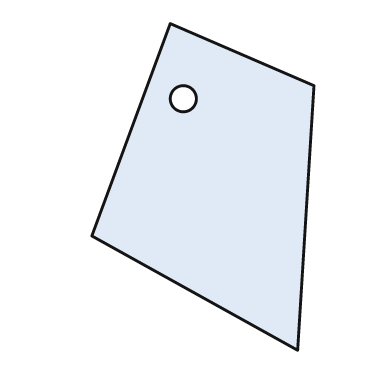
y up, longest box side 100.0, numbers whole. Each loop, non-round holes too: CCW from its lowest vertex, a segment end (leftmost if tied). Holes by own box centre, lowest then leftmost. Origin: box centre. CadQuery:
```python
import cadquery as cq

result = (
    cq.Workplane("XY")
    .moveTo(29.0, -50.0)
    .lineTo(34.0, 31.0)
    .lineTo(-10.0, 50.0)
    .lineTo(-34.0, -15.0)
    .close()
    .moveTo(-6.0, 27.0)
    .circle(4.0)
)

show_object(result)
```